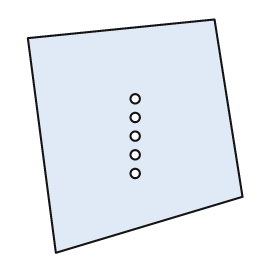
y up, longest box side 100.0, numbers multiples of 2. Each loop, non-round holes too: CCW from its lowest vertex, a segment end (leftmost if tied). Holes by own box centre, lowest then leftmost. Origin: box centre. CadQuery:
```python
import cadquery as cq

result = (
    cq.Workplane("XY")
    .moveTo(-34.0, -50.0)
    .lineTo(46.0, -26.0)
    .lineTo(34.0, 50.0)
    .lineTo(-46.0, 42.0)
    .close()
    .moveTo(0.0, -16.0)
    .circle(2.0)
    .moveTo(0.0, -8.0)
    .circle(2.0)
    .moveTo(0.0, 0.0)
    .circle(2.0)
    .moveTo(0.0, 8.0)
    .circle(2.0)
    .moveTo(0.0, 16.0)
    .circle(2.0)
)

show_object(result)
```